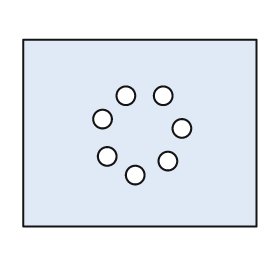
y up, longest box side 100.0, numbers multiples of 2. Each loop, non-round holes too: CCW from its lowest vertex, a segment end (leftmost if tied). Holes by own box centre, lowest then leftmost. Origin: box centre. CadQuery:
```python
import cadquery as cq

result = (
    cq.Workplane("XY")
    .moveTo(-50.0, -40.0)
    .lineTo(50.0, -40.0)
    .lineTo(50.0, 40.0)
    .lineTo(-50.0, 40.0)
    .close()
    .moveTo(-2.0, -18.0)
    .circle(4.0)
    .moveTo(12.0, -12.0)
    .circle(4.0)
    .moveTo(-14.0, -10.0)
    .circle(4.0)
    .moveTo(18.0, 2.0)
    .circle(4.0)
    .moveTo(-16.0, 6.0)
    .circle(4.0)
    .moveTo(-6.0, 16.0)
    .circle(4.0)
    .moveTo(10.0, 16.0)
    .circle(4.0)
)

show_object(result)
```